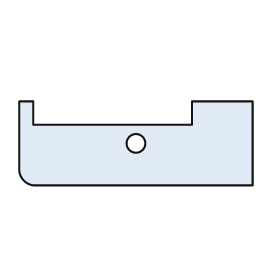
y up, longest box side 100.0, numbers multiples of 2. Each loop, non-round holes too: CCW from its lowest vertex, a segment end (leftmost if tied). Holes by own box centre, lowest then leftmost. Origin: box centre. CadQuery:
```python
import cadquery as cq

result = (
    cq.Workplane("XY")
    .moveTo(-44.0, -18.0)
    .lineTo(50.0, -18.0)
    .lineTo(50.0, 18.0)
    .lineTo(24.0, 18.0)
    .lineTo(24.0, 8.0)
    .lineTo(-44.0, 8.0)
    .lineTo(-44.0, 18.0)
    .lineTo(-50.0, 18.0)
    .lineTo(-50.0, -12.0)
    .threePointArc((-48.0, -16.0), (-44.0, -18.0))
    .close()
    .moveTo(0.0, 0.0)
    .circle(4.0)
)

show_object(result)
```